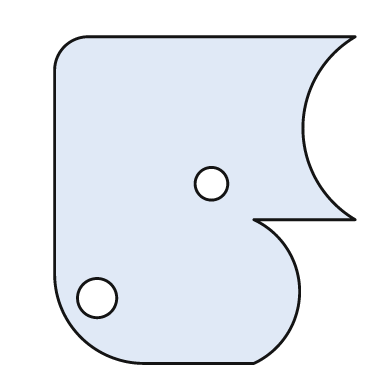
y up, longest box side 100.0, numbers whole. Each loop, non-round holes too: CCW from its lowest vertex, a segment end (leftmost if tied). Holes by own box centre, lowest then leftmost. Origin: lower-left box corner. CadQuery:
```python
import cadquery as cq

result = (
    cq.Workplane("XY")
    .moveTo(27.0, 0.0)
    .lineTo(61.0, 0.0)
    .threePointArc((75.0, 22.0), (61.0, 44.0))
    .lineTo(92.0, 44.0)
    .threePointArc((76.0, 72.0), (92.0, 100.0))
    .lineTo(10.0, 100.0)
    .threePointArc((3.0, 97.0), (0.0, 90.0))
    .lineTo(0.0, 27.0)
    .threePointArc((8.0, 8.0), (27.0, 0.0))
    .close()
    .moveTo(13.0, 20.0)
    .circle(6.0)
    .moveTo(48.0, 55.0)
    .circle(5.0)
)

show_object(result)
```